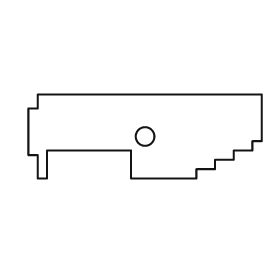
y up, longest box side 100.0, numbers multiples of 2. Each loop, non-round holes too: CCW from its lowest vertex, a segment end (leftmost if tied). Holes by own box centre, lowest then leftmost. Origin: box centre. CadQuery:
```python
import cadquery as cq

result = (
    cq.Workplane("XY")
    .moveTo(-46.0, -18.0)
    .lineTo(-42.0, -18.0)
    .lineTo(-42.0, -6.0)
    .lineTo(-6.0, -6.0)
    .lineTo(-6.0, -18.0)
    .lineTo(22.0, -18.0)
    .lineTo(22.0, -14.0)
    .lineTo(30.0, -14.0)
    .lineTo(30.0, -10.0)
    .lineTo(38.0, -10.0)
    .lineTo(38.0, -6.0)
    .lineTo(46.0, -6.0)
    .lineTo(46.0, -2.0)
    .lineTo(50.0, -2.0)
    .lineTo(50.0, 18.0)
    .lineTo(-46.0, 18.0)
    .lineTo(-46.0, 12.0)
    .lineTo(-50.0, 12.0)
    .lineTo(-50.0, -8.0)
    .lineTo(-46.0, -8.0)
    .close()
    .moveTo(0.0, 0.0)
    .circle(4.0)
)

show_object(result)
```